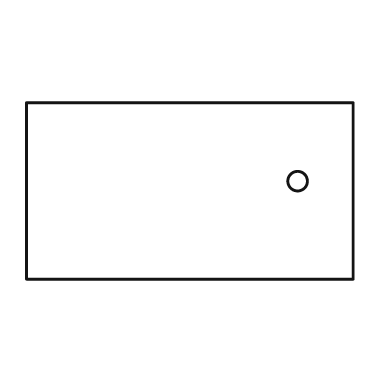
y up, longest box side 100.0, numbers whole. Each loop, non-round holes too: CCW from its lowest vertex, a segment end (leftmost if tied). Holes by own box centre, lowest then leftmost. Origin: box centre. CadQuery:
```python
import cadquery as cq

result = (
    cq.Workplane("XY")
    .moveTo(-50.0, -27.0)
    .lineTo(50.0, -27.0)
    .lineTo(50.0, 27.0)
    .lineTo(-50.0, 27.0)
    .close()
    .moveTo(33.0, 3.0)
    .circle(3.0)
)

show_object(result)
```